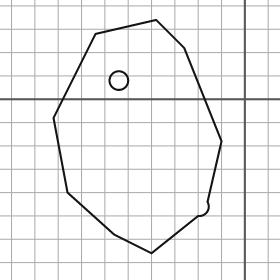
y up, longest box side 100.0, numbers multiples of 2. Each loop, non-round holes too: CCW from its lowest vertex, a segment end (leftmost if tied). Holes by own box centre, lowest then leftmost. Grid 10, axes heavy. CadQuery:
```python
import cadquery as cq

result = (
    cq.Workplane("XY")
    .moveTo(-40.0, -66.0)
    .lineTo(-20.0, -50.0)
    .threePointArc((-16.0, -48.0), (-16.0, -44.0))
    .lineTo(-10.0, -18.0)
    .lineTo(-26.0, 22.0)
    .lineTo(-38.0, 34.0)
    .lineTo(-64.0, 28.0)
    .lineTo(-82.0, -8.0)
    .lineTo(-76.0, -40.0)
    .lineTo(-56.0, -58.0)
    .close()
    .moveTo(-54.0, 8.0)
    .circle(4.0)
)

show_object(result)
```